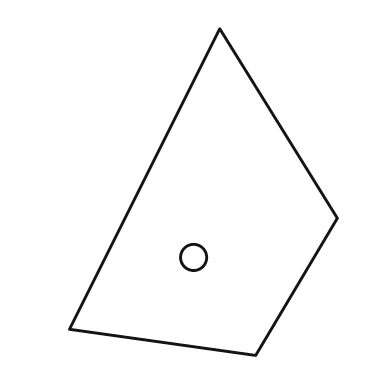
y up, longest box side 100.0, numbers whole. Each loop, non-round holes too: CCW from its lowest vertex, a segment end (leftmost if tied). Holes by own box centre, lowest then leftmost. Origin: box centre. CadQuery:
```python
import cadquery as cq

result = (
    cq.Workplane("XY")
    .moveTo(16.0, -50.0)
    .lineTo(41.0, -8.0)
    .lineTo(5.0, 50.0)
    .lineTo(-41.0, -42.0)
    .close()
    .moveTo(-3.0, -20.0)
    .circle(4.0)
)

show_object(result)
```